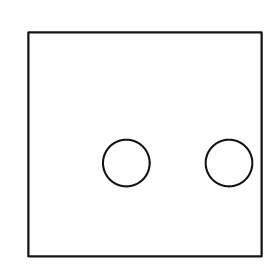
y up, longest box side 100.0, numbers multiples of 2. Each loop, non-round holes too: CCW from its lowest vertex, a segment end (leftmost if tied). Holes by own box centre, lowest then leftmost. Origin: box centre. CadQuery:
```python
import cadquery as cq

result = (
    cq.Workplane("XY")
    .moveTo(-50.0, -48.0)
    .lineTo(50.0, -48.0)
    .lineTo(50.0, 48.0)
    .lineTo(-50.0, 48.0)
    .close()
    .moveTo(-8.0, -8.0)
    .circle(10.0)
    .moveTo(36.0, -8.0)
    .circle(10.0)
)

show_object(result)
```